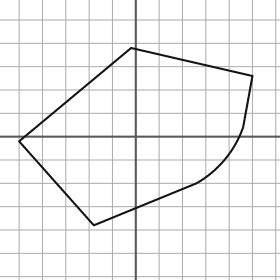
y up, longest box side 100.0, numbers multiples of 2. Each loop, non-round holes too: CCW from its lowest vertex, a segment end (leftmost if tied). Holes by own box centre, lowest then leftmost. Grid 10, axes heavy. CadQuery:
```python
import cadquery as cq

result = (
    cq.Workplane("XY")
    .moveTo(-18.0, -38.0)
    .lineTo(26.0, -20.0)
    .threePointArc((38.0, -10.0), (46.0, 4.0))
    .lineTo(50.0, 26.0)
    .lineTo(-2.0, 38.0)
    .lineTo(-50.0, -2.0)
    .close()
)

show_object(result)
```